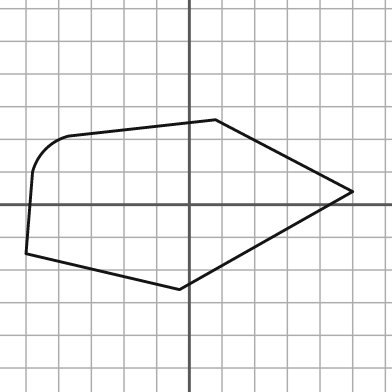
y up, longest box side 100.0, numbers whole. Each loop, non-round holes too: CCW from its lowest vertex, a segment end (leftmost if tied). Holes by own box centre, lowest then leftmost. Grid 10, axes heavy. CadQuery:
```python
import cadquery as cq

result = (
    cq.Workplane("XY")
    .moveTo(-3.0, -26.0)
    .lineTo(50.0, 4.0)
    .lineTo(8.0, 26.0)
    .lineTo(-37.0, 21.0)
    .threePointArc((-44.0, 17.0), (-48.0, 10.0))
    .lineTo(-50.0, -15.0)
    .close()
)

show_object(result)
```